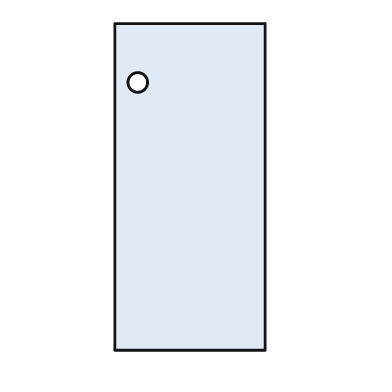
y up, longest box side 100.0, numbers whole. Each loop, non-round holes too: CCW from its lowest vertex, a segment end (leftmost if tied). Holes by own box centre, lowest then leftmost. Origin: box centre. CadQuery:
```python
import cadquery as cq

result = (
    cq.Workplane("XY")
    .moveTo(-23.0, -50.0)
    .lineTo(23.0, -50.0)
    .lineTo(23.0, 50.0)
    .lineTo(-23.0, 50.0)
    .close()
    .moveTo(-16.0, 32.0)
    .circle(3.0)
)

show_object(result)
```